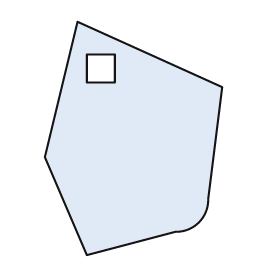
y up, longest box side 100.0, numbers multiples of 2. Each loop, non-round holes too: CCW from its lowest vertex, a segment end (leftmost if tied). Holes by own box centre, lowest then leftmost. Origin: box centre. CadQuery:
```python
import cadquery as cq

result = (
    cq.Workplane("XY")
    .moveTo(-20.0, -50.0)
    .lineTo(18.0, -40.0)
    .threePointArc((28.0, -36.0), (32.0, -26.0))
    .lineTo(38.0, 22.0)
    .lineTo(-24.0, 50.0)
    .lineTo(-38.0, -8.0)
    .close()
    .moveTo(-20.0, 24.0)
    .lineTo(-8.0, 24.0)
    .lineTo(-8.0, 36.0)
    .lineTo(-20.0, 36.0)
    .close()
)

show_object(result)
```